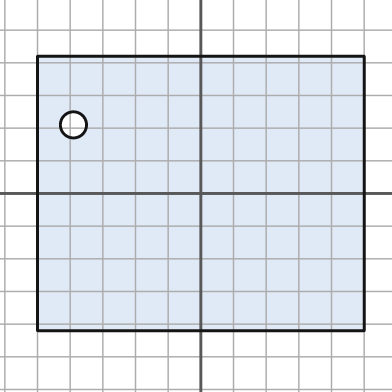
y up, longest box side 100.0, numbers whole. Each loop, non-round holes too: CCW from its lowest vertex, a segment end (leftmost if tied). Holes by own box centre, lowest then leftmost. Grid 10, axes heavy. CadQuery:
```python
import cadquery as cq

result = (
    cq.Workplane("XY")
    .moveTo(-50.0, -42.0)
    .lineTo(50.0, -42.0)
    .lineTo(50.0, 42.0)
    .lineTo(-50.0, 42.0)
    .close()
    .moveTo(-39.0, 21.0)
    .circle(4.0)
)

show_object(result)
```